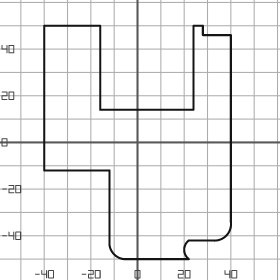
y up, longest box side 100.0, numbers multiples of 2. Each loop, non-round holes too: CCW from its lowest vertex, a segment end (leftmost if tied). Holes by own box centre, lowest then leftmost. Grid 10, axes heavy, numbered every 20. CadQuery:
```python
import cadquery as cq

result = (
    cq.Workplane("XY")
    .moveTo(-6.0, -50.0)
    .lineTo(22.0, -50.0)
    .threePointArc((20.0, -46.0), (22.0, -42.0))
    .lineTo(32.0, -42.0)
    .threePointArc((38.0, -40.0), (40.0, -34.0))
    .lineTo(40.0, 46.0)
    .lineTo(28.0, 46.0)
    .lineTo(28.0, 50.0)
    .lineTo(24.0, 50.0)
    .lineTo(24.0, 14.0)
    .lineTo(-16.0, 14.0)
    .lineTo(-16.0, 50.0)
    .lineTo(-40.0, 50.0)
    .lineTo(-40.0, -12.0)
    .lineTo(-12.0, -12.0)
    .lineTo(-12.0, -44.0)
    .threePointArc((-10.0, -48.0), (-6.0, -50.0))
    .close()
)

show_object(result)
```